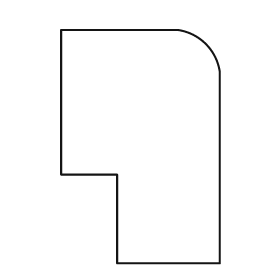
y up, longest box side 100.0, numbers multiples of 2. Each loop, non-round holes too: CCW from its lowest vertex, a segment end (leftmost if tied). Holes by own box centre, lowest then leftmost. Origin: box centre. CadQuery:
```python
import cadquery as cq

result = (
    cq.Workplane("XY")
    .moveTo(-10.0, -50.0)
    .lineTo(34.0, -50.0)
    .lineTo(34.0, 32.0)
    .threePointArc((28.0, 44.0), (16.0, 50.0))
    .lineTo(-34.0, 50.0)
    .lineTo(-34.0, -12.0)
    .lineTo(-10.0, -12.0)
    .close()
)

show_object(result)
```